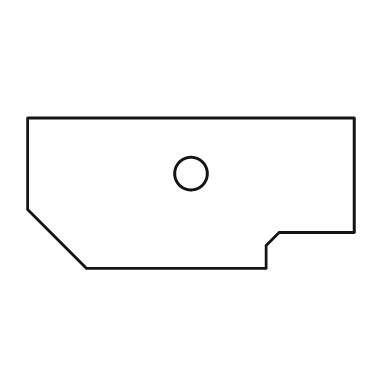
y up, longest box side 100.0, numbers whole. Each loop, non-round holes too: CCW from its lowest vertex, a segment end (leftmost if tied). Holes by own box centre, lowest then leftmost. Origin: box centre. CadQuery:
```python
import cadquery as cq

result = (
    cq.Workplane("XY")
    .moveTo(-32.0, -23.0)
    .lineTo(23.0, -23.0)
    .lineTo(23.0, -16.0)
    .lineTo(27.0, -12.0)
    .lineTo(50.0, -12.0)
    .lineTo(50.0, 23.0)
    .lineTo(-50.0, 23.0)
    .lineTo(-50.0, -5.0)
    .close()
    .moveTo(0.0, 6.0)
    .circle(5.0)
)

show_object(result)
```